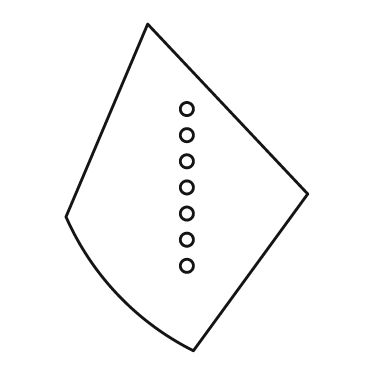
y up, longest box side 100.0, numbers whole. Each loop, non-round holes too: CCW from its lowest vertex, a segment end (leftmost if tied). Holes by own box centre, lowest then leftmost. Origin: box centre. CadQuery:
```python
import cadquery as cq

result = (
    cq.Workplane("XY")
    .moveTo(2.0, -50.0)
    .lineTo(37.0, -2.0)
    .lineTo(-12.0, 50.0)
    .lineTo(-37.0, -9.0)
    .threePointArc((-21.0, -33.0), (2.0, -50.0))
    .close()
    .moveTo(0.0, -24.0)
    .circle(2.0)
    .moveTo(0.0, -16.0)
    .circle(2.0)
    .moveTo(0.0, -8.0)
    .circle(2.0)
    .moveTo(0.0, 0.0)
    .circle(2.0)
    .moveTo(0.0, 8.0)
    .circle(2.0)
    .moveTo(0.0, 16.0)
    .circle(2.0)
    .moveTo(0.0, 24.0)
    .circle(2.0)
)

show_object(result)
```